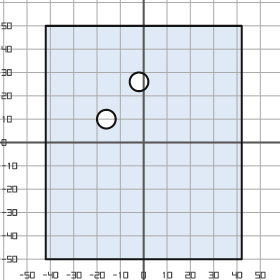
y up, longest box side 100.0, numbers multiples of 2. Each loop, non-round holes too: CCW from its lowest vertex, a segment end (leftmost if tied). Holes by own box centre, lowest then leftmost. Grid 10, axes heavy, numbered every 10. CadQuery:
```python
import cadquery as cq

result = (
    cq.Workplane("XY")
    .moveTo(-42.0, -50.0)
    .lineTo(42.0, -50.0)
    .lineTo(42.0, 50.0)
    .lineTo(-42.0, 50.0)
    .close()
    .moveTo(-16.0, 10.0)
    .circle(4.0)
    .moveTo(-2.0, 26.0)
    .circle(4.0)
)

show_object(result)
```